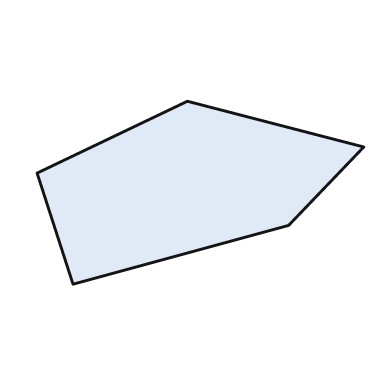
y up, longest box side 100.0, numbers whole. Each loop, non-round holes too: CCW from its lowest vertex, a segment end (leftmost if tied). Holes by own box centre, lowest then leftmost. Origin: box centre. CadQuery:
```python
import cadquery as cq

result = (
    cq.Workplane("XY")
    .moveTo(-39.0, -28.0)
    .lineTo(27.0, -10.0)
    .lineTo(50.0, 14.0)
    .lineTo(-4.0, 28.0)
    .lineTo(-50.0, 6.0)
    .close()
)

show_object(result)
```